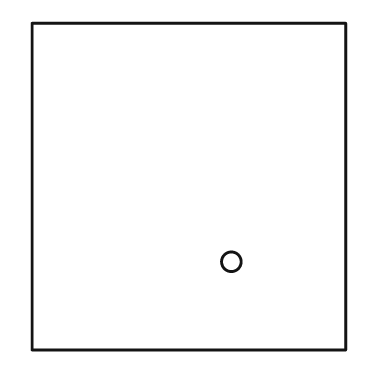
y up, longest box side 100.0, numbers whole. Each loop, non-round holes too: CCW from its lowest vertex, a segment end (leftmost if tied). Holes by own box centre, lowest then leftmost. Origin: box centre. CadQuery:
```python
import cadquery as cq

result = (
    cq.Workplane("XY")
    .moveTo(-48.0, -50.0)
    .lineTo(48.0, -50.0)
    .lineTo(48.0, 50.0)
    .lineTo(-48.0, 50.0)
    .close()
    .moveTo(13.0, -23.0)
    .circle(3.0)
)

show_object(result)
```